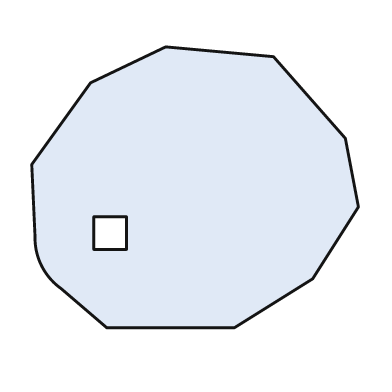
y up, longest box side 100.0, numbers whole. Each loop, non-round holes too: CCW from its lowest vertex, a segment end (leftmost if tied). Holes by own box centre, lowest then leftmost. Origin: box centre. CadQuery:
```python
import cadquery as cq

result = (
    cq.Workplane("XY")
    .moveTo(-27.0, -43.0)
    .lineTo(12.0, -43.0)
    .lineTo(36.0, -28.0)
    .lineTo(50.0, -6.0)
    .lineTo(46.0, 15.0)
    .lineTo(24.0, 40.0)
    .lineTo(-9.0, 43.0)
    .lineTo(-32.0, 32.0)
    .lineTo(-50.0, 7.0)
    .lineTo(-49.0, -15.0)
    .threePointArc((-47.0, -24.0), (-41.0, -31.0))
    .close()
    .moveTo(-31.0, -19.0)
    .lineTo(-21.0, -19.0)
    .lineTo(-21.0, -9.0)
    .lineTo(-31.0, -9.0)
    .close()
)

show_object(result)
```